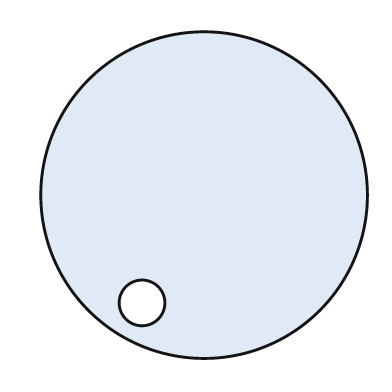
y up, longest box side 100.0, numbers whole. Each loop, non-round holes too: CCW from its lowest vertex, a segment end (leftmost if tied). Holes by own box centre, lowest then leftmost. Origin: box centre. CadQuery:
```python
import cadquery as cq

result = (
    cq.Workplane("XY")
    .moveTo(0.0, 0.0)
    .circle(50.0)
    .moveTo(-19.0, -33.0)
    .circle(7.0)
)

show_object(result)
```